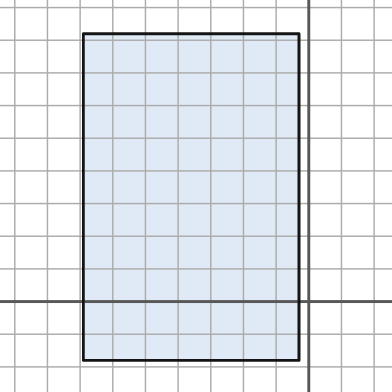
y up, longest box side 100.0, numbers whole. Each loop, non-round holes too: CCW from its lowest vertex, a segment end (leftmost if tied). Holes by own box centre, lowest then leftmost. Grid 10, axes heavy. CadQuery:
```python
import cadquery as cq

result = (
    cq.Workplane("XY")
    .moveTo(-69.0, -18.0)
    .lineTo(-3.0, -18.0)
    .lineTo(-3.0, 82.0)
    .lineTo(-69.0, 82.0)
    .close()
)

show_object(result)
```